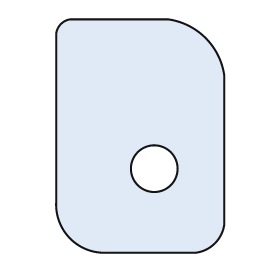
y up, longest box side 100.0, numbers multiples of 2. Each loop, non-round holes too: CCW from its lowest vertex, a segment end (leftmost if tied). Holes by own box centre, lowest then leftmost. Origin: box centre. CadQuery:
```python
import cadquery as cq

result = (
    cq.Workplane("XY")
    .moveTo(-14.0, -50.0)
    .lineTo(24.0, -50.0)
    .threePointArc((32.0, -46.0), (36.0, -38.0))
    .lineTo(36.0, 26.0)
    .threePointArc((28.0, 42.0), (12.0, 50.0))
    .lineTo(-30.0, 50.0)
    .threePointArc((-34.0, 48.0), (-36.0, 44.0))
    .lineTo(-36.0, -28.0)
    .threePointArc((-30.0, -44.0), (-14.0, -50.0))
    .close()
    .moveTo(6.0, -14.0)
    .circle(10.0)
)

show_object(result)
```